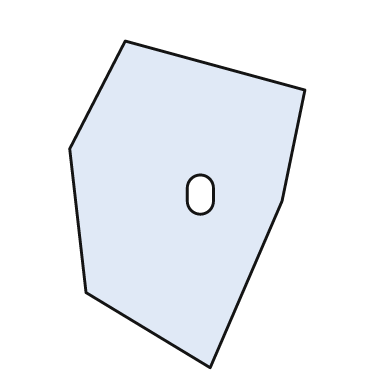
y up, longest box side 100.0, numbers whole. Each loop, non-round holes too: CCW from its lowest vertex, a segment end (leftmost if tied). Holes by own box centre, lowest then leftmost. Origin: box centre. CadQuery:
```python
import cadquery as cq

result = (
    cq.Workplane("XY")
    .moveTo(7.0, -50.0)
    .lineTo(29.0, 1.0)
    .lineTo(36.0, 35.0)
    .lineTo(-19.0, 50.0)
    .lineTo(-36.0, 17.0)
    .lineTo(-31.0, -27.0)
    .close()
    .moveTo(0.0, 1.0)
    .threePointArc((4.0, -3.0), (8.0, 1.0))
    .lineTo(8.0, 5.0)
    .threePointArc((4.0, 9.0), (0.0, 5.0))
    .close()
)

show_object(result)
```